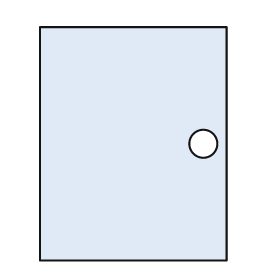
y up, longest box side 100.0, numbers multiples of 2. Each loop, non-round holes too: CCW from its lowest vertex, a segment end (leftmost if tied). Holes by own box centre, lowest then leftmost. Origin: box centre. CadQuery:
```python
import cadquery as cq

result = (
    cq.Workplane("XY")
    .moveTo(-40.0, -50.0)
    .lineTo(40.0, -50.0)
    .lineTo(40.0, 50.0)
    .lineTo(-40.0, 50.0)
    .close()
    .moveTo(30.0, 0.0)
    .circle(6.0)
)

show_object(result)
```